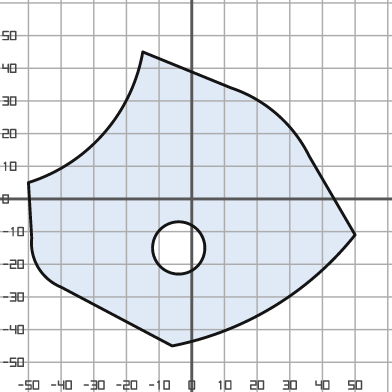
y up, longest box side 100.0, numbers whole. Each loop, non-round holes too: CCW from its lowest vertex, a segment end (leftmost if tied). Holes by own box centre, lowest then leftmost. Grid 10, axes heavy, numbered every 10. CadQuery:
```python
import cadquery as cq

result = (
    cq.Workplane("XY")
    .moveTo(-6.0, -45.0)
    .threePointArc((25.0, -33.0), (50.0, -11.0))
    .lineTo(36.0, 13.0)
    .threePointArc((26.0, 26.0), (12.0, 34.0))
    .lineTo(-15.0, 45.0)
    .threePointArc((-27.0, 20.0), (-50.0, 5.0))
    .lineTo(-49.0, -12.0)
    .threePointArc((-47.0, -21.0), (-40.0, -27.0))
    .close()
    .moveTo(-4.0, -15.0)
    .circle(8.0)
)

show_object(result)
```